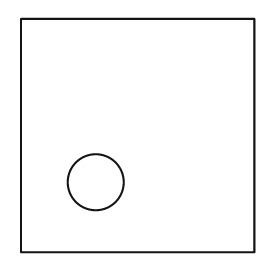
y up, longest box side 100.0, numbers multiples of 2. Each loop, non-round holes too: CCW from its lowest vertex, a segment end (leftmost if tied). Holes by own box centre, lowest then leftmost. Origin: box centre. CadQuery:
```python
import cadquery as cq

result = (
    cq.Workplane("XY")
    .moveTo(-50.0, -50.0)
    .lineTo(50.0, -50.0)
    .lineTo(50.0, 50.0)
    .lineTo(-50.0, 50.0)
    .close()
    .moveTo(-18.0, -20.0)
    .circle(12.0)
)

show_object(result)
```